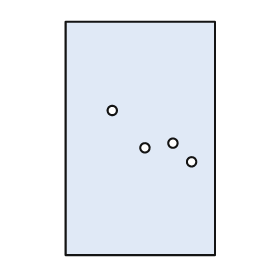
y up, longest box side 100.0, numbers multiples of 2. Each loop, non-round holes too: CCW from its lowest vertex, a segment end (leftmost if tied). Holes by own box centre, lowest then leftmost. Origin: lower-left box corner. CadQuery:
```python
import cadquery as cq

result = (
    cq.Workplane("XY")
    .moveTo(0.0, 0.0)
    .lineTo(64.0, 0.0)
    .lineTo(64.0, 100.0)
    .lineTo(0.0, 100.0)
    .close()
    .moveTo(54.0, 40.0)
    .circle(2.0)
    .moveTo(34.0, 46.0)
    .circle(2.0)
    .moveTo(46.0, 48.0)
    .circle(2.0)
    .moveTo(20.0, 62.0)
    .circle(2.0)
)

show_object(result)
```